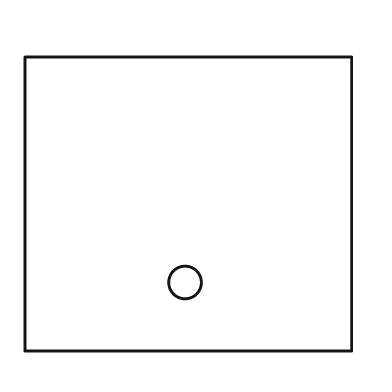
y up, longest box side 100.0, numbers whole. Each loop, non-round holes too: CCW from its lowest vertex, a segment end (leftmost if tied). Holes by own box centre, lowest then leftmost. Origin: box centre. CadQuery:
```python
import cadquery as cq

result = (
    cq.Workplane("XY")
    .moveTo(-50.0, -45.0)
    .lineTo(50.0, -45.0)
    .lineTo(50.0, 45.0)
    .lineTo(-50.0, 45.0)
    .close()
    .moveTo(-1.0, -24.0)
    .circle(5.0)
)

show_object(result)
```